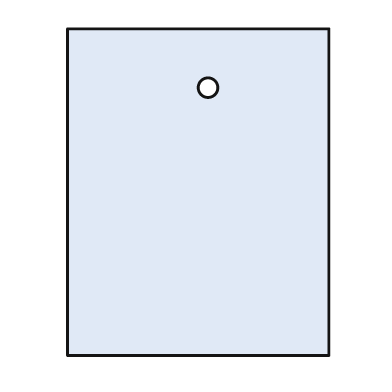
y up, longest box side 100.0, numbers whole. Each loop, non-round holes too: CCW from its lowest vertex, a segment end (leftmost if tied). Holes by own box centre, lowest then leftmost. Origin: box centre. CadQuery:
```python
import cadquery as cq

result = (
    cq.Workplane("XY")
    .moveTo(-40.0, -50.0)
    .lineTo(40.0, -50.0)
    .lineTo(40.0, 50.0)
    .lineTo(-40.0, 50.0)
    .close()
    .moveTo(3.0, 32.0)
    .circle(3.0)
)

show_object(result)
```